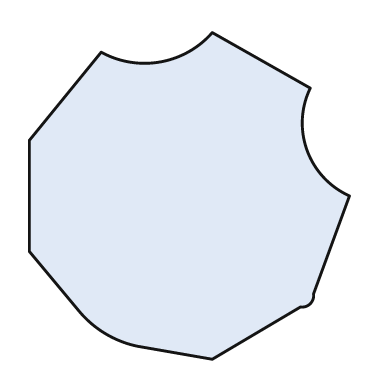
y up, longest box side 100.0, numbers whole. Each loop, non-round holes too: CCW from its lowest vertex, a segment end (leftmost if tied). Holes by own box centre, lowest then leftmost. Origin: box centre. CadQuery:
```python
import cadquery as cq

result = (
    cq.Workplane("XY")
    .moveTo(7.0, -50.0)
    .lineTo(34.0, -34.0)
    .threePointArc((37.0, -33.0), (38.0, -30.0))
    .lineTo(49.0, 0.0)
    .threePointArc((36.0, 14.0), (37.0, 33.0))
    .lineTo(7.0, 50.0)
    .threePointArc((-9.0, 41.0), (-27.0, 44.0))
    .lineTo(-49.0, 17.0)
    .lineTo(-49.0, -17.0)
    .lineTo(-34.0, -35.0)
    .threePointArc((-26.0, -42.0), (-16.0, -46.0))
    .close()
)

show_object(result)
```